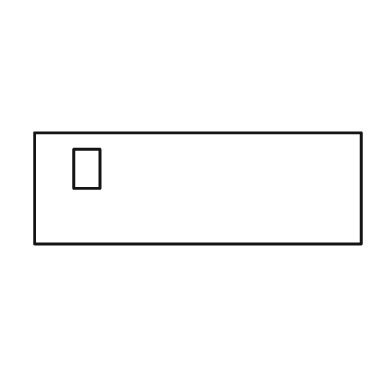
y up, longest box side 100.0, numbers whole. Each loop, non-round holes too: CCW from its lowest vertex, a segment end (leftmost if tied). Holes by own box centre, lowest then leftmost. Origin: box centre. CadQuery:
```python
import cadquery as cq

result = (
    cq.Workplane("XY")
    .moveTo(-50.0, -17.0)
    .lineTo(50.0, -17.0)
    .lineTo(50.0, 17.0)
    .lineTo(-50.0, 17.0)
    .close()
    .moveTo(-38.0, 0.0)
    .lineTo(-30.0, 0.0)
    .lineTo(-30.0, 12.0)
    .lineTo(-38.0, 12.0)
    .close()
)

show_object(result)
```